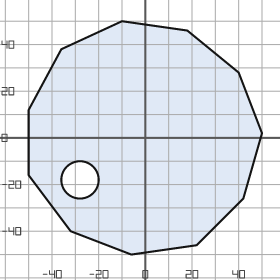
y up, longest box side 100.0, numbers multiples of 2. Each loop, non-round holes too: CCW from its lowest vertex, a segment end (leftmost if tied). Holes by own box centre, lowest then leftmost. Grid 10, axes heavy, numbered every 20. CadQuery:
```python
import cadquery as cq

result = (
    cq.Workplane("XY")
    .moveTo(-6.0, -50.0)
    .lineTo(22.0, -46.0)
    .lineTo(42.0, -26.0)
    .lineTo(50.0, 2.0)
    .lineTo(40.0, 28.0)
    .lineTo(18.0, 46.0)
    .lineTo(-10.0, 50.0)
    .lineTo(-36.0, 38.0)
    .lineTo(-50.0, 12.0)
    .lineTo(-50.0, -16.0)
    .lineTo(-32.0, -40.0)
    .close()
    .moveTo(-28.0, -18.0)
    .circle(8.0)
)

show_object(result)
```